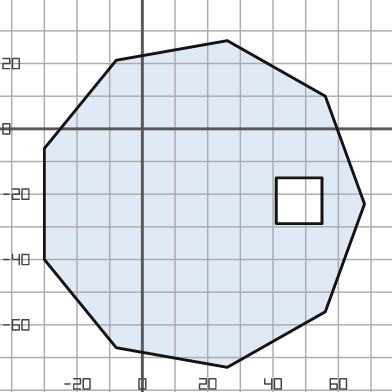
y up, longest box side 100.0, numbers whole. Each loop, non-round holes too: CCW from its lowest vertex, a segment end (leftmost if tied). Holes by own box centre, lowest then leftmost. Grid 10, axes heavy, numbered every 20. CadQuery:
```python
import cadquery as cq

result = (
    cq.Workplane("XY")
    .moveTo(26.0, -73.0)
    .lineTo(56.0, -56.0)
    .lineTo(68.0, -23.0)
    .lineTo(56.0, 10.0)
    .lineTo(26.0, 27.0)
    .lineTo(-8.0, 21.0)
    .lineTo(-30.0, -6.0)
    .lineTo(-30.0, -40.0)
    .lineTo(-8.0, -67.0)
    .close()
    .moveTo(41.0, -29.0)
    .lineTo(55.0, -29.0)
    .lineTo(55.0, -15.0)
    .lineTo(41.0, -15.0)
    .close()
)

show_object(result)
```